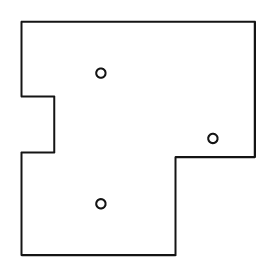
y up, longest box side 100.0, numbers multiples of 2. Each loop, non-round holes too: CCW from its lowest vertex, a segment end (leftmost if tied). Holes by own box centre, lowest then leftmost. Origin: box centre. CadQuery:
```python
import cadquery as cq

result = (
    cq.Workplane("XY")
    .moveTo(-50.0, -50.0)
    .lineTo(16.0, -50.0)
    .lineTo(16.0, -8.0)
    .lineTo(50.0, -8.0)
    .lineTo(50.0, 50.0)
    .lineTo(-50.0, 50.0)
    .lineTo(-50.0, 18.0)
    .lineTo(-36.0, 18.0)
    .lineTo(-36.0, -6.0)
    .lineTo(-50.0, -6.0)
    .close()
    .moveTo(-16.0, -28.0)
    .circle(2.0)
    .moveTo(32.0, 0.0)
    .circle(2.0)
    .moveTo(-16.0, 28.0)
    .circle(2.0)
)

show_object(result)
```